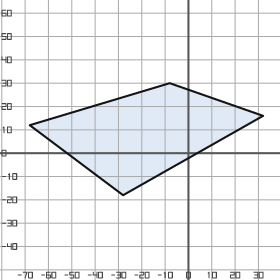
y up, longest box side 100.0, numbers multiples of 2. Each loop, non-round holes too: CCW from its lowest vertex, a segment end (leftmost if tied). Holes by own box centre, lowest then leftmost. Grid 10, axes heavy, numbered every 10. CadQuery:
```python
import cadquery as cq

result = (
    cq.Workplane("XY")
    .moveTo(-28.0, -18.0)
    .lineTo(32.0, 16.0)
    .lineTo(-8.0, 30.0)
    .lineTo(-68.0, 12.0)
    .close()
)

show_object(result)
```